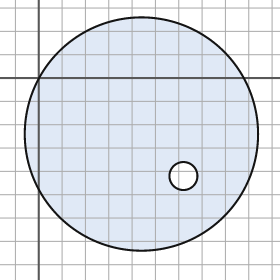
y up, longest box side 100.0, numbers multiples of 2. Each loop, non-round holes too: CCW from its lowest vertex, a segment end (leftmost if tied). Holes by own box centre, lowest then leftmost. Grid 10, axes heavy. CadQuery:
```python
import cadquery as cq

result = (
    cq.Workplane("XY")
    .moveTo(44.0, -24.0)
    .circle(50.0)
    .moveTo(62.0, -42.0)
    .circle(6.0)
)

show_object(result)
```